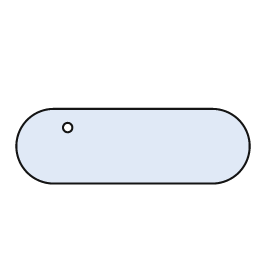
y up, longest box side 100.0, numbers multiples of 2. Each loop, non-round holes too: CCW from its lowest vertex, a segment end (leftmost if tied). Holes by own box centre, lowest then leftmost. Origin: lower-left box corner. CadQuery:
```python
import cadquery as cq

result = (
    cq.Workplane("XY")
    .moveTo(16.0, 0.0)
    .lineTo(84.0, 0.0)
    .threePointArc((100.0, 16.0), (84.0, 32.0))
    .lineTo(16.0, 32.0)
    .threePointArc((0.0, 16.0), (16.0, 0.0))
    .close()
    .moveTo(22.0, 24.0)
    .circle(2.0)
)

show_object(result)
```